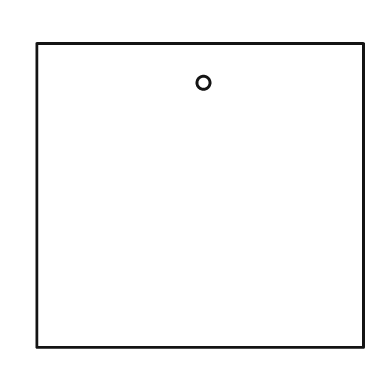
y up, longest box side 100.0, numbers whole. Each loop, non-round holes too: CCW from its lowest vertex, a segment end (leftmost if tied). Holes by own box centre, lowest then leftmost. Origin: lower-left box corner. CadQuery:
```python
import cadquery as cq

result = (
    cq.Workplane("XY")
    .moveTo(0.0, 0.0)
    .lineTo(100.0, 0.0)
    .lineTo(100.0, 93.0)
    .lineTo(0.0, 93.0)
    .close()
    .moveTo(51.0, 81.0)
    .circle(2.0)
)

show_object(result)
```